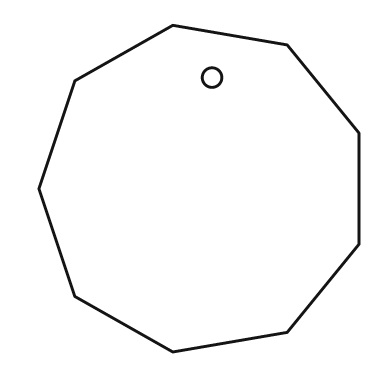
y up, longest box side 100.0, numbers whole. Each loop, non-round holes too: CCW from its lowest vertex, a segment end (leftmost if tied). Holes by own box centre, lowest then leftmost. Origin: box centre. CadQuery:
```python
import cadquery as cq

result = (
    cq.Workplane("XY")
    .moveTo(-8.0, -50.0)
    .lineTo(27.0, -44.0)
    .lineTo(49.0, -17.0)
    .lineTo(49.0, 17.0)
    .lineTo(27.0, 44.0)
    .lineTo(-8.0, 50.0)
    .lineTo(-38.0, 33.0)
    .lineTo(-49.0, 0.0)
    .lineTo(-38.0, -33.0)
    .close()
    .moveTo(4.0, 34.0)
    .circle(3.0)
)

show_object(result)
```